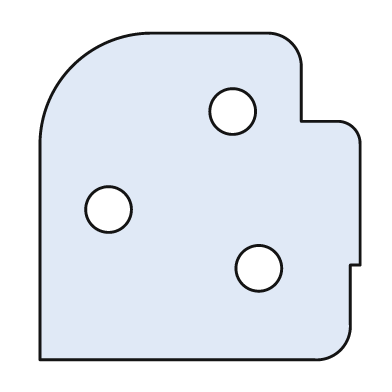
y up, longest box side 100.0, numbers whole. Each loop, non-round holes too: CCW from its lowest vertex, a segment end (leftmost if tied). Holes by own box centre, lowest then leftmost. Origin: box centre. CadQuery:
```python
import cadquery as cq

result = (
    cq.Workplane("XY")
    .moveTo(-49.0, -50.0)
    .lineTo(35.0, -50.0)
    .threePointArc((43.0, -47.0), (46.0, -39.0))
    .lineTo(46.0, -21.0)
    .lineTo(49.0, -21.0)
    .lineTo(49.0, 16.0)
    .threePointArc((47.0, 21.0), (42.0, 23.0))
    .lineTo(31.0, 23.0)
    .lineTo(31.0, 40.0)
    .threePointArc((28.0, 47.0), (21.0, 50.0))
    .lineTo(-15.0, 50.0)
    .threePointArc((-39.0, 40.0), (-49.0, 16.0))
    .close()
    .moveTo(18.0, -22.0)
    .circle(7.0)
    .moveTo(-28.0, -4.0)
    .circle(7.0)
    .moveTo(10.0, 26.0)
    .circle(7.0)
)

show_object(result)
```